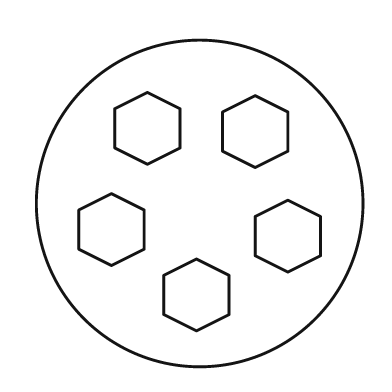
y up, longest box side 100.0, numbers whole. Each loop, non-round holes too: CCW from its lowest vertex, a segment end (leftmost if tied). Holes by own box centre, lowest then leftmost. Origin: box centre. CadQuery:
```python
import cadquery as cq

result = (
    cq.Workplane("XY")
    .moveTo(0.0, 0.0)
    .circle(50.0)
    .moveTo(-1.0, -39.0)
    .lineTo(9.0, -34.0)
    .lineTo(9.0, -22.0)
    .lineTo(-1.0, -17.0)
    .lineTo(-11.0, -22.0)
    .lineTo(-11.0, -34.0)
    .close()
    .moveTo(27.0, -21.0)
    .lineTo(37.0, -16.0)
    .lineTo(37.0, -4.0)
    .lineTo(27.0, 1.0)
    .lineTo(17.0, -4.0)
    .lineTo(17.0, -16.0)
    .close()
    .moveTo(-27.0, -19.0)
    .lineTo(-17.0, -14.0)
    .lineTo(-17.0, -2.0)
    .lineTo(-27.0, 3.0)
    .lineTo(-37.0, -2.0)
    .lineTo(-37.0, -14.0)
    .close()
    .moveTo(17.0, 11.0)
    .lineTo(27.0, 16.0)
    .lineTo(27.0, 28.0)
    .lineTo(17.0, 33.0)
    .lineTo(7.0, 28.0)
    .lineTo(7.0, 16.0)
    .close()
    .moveTo(-16.0, 12.0)
    .lineTo(-6.0, 17.0)
    .lineTo(-6.0, 29.0)
    .lineTo(-16.0, 34.0)
    .lineTo(-26.0, 29.0)
    .lineTo(-26.0, 17.0)
    .close()
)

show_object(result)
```